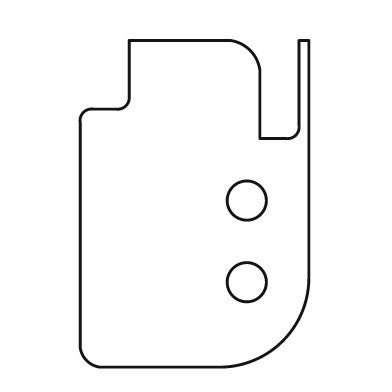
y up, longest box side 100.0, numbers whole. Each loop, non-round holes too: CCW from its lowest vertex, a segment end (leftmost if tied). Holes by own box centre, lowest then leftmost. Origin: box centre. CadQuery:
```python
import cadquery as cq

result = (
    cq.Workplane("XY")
    .moveTo(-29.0, -50.0)
    .lineTo(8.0, -50.0)
    .threePointArc((27.0, -42.0), (35.0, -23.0))
    .lineTo(35.0, 50.0)
    .lineTo(32.0, 50.0)
    .lineTo(32.0, 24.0)
    .threePointArc((31.0, 21.0), (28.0, 20.0))
    .lineTo(20.0, 20.0)
    .lineTo(20.0, 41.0)
    .threePointArc((17.0, 47.0), (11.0, 50.0))
    .lineTo(-20.0, 50.0)
    .lineTo(-20.0, 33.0)
    .threePointArc((-21.0, 30.0), (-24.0, 29.0))
    .lineTo(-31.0, 29.0)
    .threePointArc((-34.0, 28.0), (-35.0, 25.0))
    .lineTo(-35.0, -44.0)
    .threePointArc((-33.0, -48.0), (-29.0, -50.0))
    .close()
    .moveTo(16.0, -24.0)
    .circle(6.0)
    .moveTo(16.0, 1.0)
    .circle(6.0)
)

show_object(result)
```